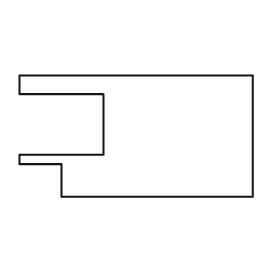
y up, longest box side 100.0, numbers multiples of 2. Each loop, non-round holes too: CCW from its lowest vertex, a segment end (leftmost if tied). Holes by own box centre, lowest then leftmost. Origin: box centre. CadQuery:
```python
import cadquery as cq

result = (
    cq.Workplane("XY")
    .moveTo(-32.0, -26.0)
    .lineTo(50.0, -26.0)
    .lineTo(50.0, 26.0)
    .lineTo(-50.0, 26.0)
    .lineTo(-50.0, 18.0)
    .lineTo(-14.0, 18.0)
    .lineTo(-14.0, -8.0)
    .lineTo(-50.0, -8.0)
    .lineTo(-50.0, -12.0)
    .lineTo(-32.0, -12.0)
    .close()
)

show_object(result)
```